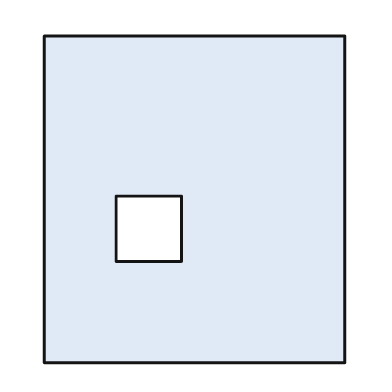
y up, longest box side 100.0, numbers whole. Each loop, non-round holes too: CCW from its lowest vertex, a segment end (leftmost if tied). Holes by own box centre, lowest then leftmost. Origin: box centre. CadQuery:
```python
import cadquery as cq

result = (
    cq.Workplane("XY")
    .moveTo(-46.0, -50.0)
    .lineTo(46.0, -50.0)
    .lineTo(46.0, 50.0)
    .lineTo(-46.0, 50.0)
    .close()
    .moveTo(-24.0, -19.0)
    .lineTo(-4.0, -19.0)
    .lineTo(-4.0, 1.0)
    .lineTo(-24.0, 1.0)
    .close()
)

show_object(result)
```